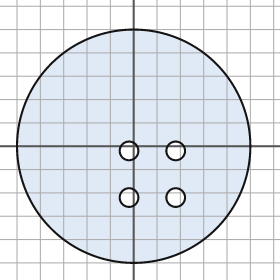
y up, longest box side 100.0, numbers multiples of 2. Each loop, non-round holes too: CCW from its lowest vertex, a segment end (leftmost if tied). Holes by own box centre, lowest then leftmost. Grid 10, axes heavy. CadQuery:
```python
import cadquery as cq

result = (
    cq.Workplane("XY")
    .moveTo(0.0, 0.0)
    .circle(50.0)
    .moveTo(-2.0, -22.0)
    .circle(4.0)
    .moveTo(18.0, -22.0)
    .circle(4.0)
    .moveTo(-2.0, -2.0)
    .circle(4.0)
    .moveTo(18.0, -2.0)
    .circle(4.0)
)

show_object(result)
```